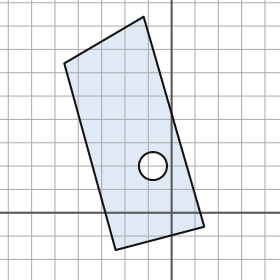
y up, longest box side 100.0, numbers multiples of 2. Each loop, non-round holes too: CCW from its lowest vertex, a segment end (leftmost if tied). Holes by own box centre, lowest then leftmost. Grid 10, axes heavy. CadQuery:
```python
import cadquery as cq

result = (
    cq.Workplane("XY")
    .moveTo(-24.0, -16.0)
    .lineTo(14.0, -6.0)
    .lineTo(-12.0, 84.0)
    .lineTo(-46.0, 64.0)
    .close()
    .moveTo(-8.0, 20.0)
    .circle(6.0)
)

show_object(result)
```